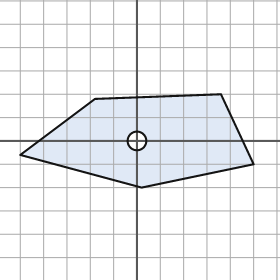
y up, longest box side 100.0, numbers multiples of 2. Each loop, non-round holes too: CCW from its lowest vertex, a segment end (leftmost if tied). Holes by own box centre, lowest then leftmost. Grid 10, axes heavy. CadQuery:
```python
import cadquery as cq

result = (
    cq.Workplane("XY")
    .moveTo(2.0, -20.0)
    .lineTo(50.0, -10.0)
    .lineTo(36.0, 20.0)
    .lineTo(-18.0, 18.0)
    .lineTo(-50.0, -6.0)
    .close()
    .moveTo(0.0, 0.0)
    .circle(4.0)
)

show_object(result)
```